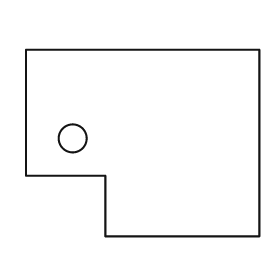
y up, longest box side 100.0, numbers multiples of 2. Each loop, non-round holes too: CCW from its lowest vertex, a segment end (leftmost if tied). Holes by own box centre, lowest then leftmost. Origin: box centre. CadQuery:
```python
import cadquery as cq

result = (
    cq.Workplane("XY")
    .moveTo(-16.0, -40.0)
    .lineTo(50.0, -40.0)
    .lineTo(50.0, 40.0)
    .lineTo(-50.0, 40.0)
    .lineTo(-50.0, -14.0)
    .lineTo(-16.0, -14.0)
    .close()
    .moveTo(-30.0, 2.0)
    .circle(6.0)
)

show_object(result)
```